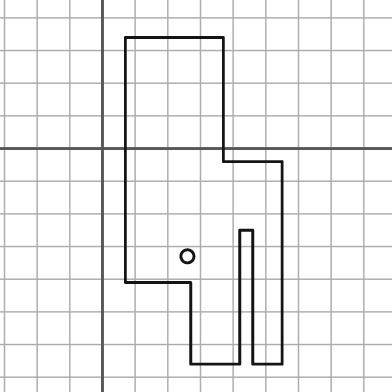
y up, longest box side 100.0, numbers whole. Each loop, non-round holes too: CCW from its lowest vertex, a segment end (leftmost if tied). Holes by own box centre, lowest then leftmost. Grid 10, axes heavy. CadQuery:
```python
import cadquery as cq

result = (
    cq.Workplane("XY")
    .moveTo(27.0, -66.0)
    .lineTo(42.0, -66.0)
    .lineTo(42.0, -25.0)
    .lineTo(46.0, -25.0)
    .lineTo(46.0, -66.0)
    .lineTo(55.0, -66.0)
    .lineTo(55.0, -4.0)
    .lineTo(37.0, -4.0)
    .lineTo(37.0, 34.0)
    .lineTo(7.0, 34.0)
    .lineTo(7.0, -41.0)
    .lineTo(27.0, -41.0)
    .close()
    .moveTo(26.0, -33.0)
    .circle(2.0)
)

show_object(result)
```